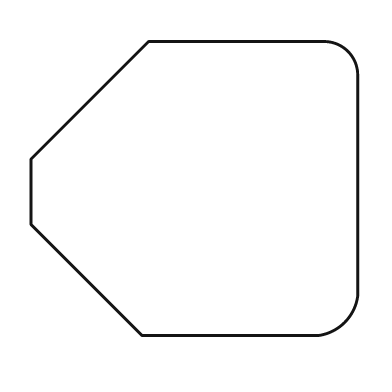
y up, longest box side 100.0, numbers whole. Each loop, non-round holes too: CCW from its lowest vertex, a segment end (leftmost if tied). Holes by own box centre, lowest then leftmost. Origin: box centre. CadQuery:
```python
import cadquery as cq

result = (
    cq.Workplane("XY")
    .moveTo(-16.0, -45.0)
    .lineTo(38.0, -45.0)
    .threePointArc((46.0, -41.0), (50.0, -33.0))
    .lineTo(50.0, 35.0)
    .threePointArc((47.0, 42.0), (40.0, 45.0))
    .lineTo(-14.0, 45.0)
    .lineTo(-50.0, 9.0)
    .lineTo(-50.0, -11.0)
    .close()
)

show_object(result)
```